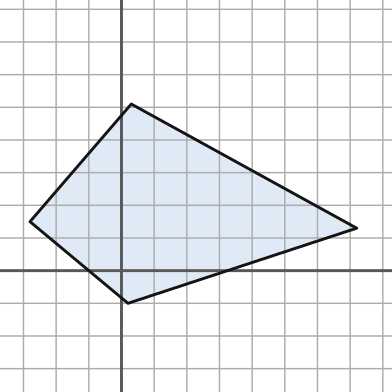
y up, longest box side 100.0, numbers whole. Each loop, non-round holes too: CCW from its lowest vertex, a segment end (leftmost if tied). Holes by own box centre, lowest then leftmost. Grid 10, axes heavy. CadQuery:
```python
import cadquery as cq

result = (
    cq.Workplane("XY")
    .moveTo(2.0, -10.0)
    .lineTo(72.0, 13.0)
    .lineTo(3.0, 51.0)
    .lineTo(-28.0, 15.0)
    .close()
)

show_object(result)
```